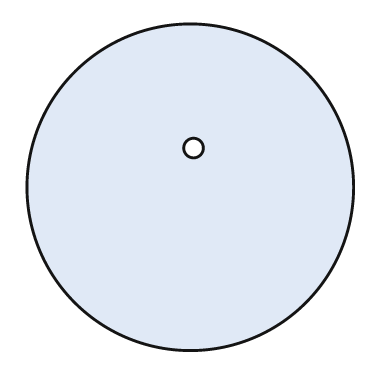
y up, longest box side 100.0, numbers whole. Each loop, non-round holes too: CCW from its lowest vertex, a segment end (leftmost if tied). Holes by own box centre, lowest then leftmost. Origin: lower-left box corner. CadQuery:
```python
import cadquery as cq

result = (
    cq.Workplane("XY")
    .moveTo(50.0, 50.0)
    .circle(50.0)
    .moveTo(51.0, 62.0)
    .circle(3.0)
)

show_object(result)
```